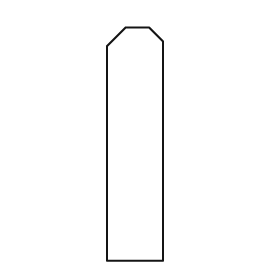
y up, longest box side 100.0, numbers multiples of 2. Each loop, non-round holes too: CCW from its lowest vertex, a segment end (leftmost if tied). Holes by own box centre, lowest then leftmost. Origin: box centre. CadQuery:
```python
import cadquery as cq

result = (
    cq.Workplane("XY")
    .moveTo(-12.0, -50.0)
    .lineTo(12.0, -50.0)
    .lineTo(12.0, 44.0)
    .lineTo(6.0, 50.0)
    .lineTo(-4.0, 50.0)
    .lineTo(-12.0, 42.0)
    .close()
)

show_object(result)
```